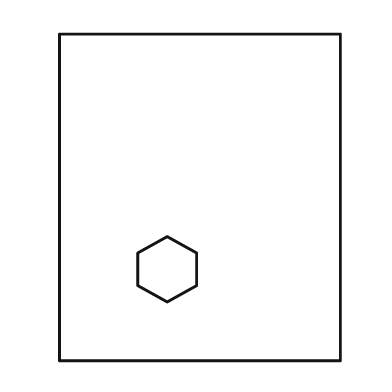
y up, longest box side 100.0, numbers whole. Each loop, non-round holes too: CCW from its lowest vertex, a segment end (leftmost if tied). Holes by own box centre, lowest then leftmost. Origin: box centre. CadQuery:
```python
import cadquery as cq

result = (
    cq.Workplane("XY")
    .moveTo(-43.0, -50.0)
    .lineTo(43.0, -50.0)
    .lineTo(43.0, 50.0)
    .lineTo(-43.0, 50.0)
    .close()
    .moveTo(-10.0, -32.0)
    .lineTo(-1.0, -27.0)
    .lineTo(-1.0, -17.0)
    .lineTo(-10.0, -12.0)
    .lineTo(-19.0, -17.0)
    .lineTo(-19.0, -27.0)
    .close()
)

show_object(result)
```